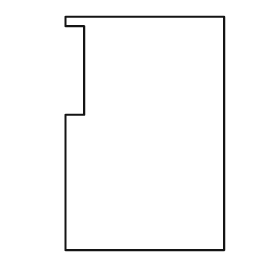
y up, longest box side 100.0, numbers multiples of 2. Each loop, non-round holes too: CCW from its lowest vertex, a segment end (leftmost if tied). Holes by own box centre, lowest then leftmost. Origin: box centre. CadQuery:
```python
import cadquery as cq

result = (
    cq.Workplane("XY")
    .moveTo(-34.0, -50.0)
    .lineTo(34.0, -50.0)
    .lineTo(34.0, 50.0)
    .lineTo(-34.0, 50.0)
    .lineTo(-34.0, 46.0)
    .lineTo(-26.0, 46.0)
    .lineTo(-26.0, 8.0)
    .lineTo(-34.0, 8.0)
    .close()
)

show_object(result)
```